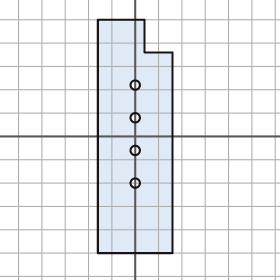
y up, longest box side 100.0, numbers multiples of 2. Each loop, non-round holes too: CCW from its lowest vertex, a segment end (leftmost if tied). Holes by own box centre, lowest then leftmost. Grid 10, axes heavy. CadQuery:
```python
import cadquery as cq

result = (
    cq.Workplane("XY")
    .moveTo(-16.0, -50.0)
    .lineTo(16.0, -50.0)
    .lineTo(16.0, 36.0)
    .lineTo(4.0, 36.0)
    .lineTo(4.0, 50.0)
    .lineTo(-16.0, 50.0)
    .close()
    .moveTo(0.0, -20.0)
    .circle(2.0)
    .moveTo(0.0, -6.0)
    .circle(2.0)
    .moveTo(0.0, 8.0)
    .circle(2.0)
    .moveTo(0.0, 22.0)
    .circle(2.0)
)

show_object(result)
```